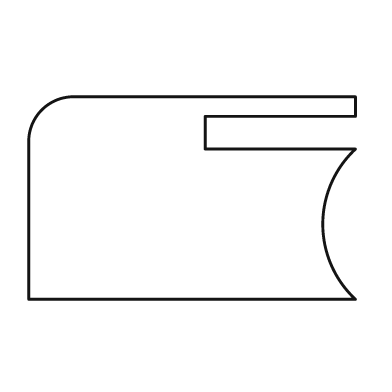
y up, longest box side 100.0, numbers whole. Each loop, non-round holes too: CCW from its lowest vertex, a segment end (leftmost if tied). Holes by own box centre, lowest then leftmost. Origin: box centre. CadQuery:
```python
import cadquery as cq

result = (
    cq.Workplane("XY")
    .moveTo(-50.0, -31.0)
    .lineTo(50.0, -31.0)
    .threePointArc((40.0, -8.0), (50.0, 15.0))
    .lineTo(4.0, 15.0)
    .lineTo(4.0, 25.0)
    .lineTo(50.0, 25.0)
    .lineTo(50.0, 31.0)
    .lineTo(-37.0, 31.0)
    .threePointArc((-46.0, 27.0), (-50.0, 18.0))
    .close()
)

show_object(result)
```